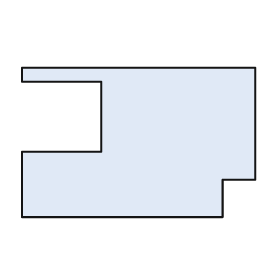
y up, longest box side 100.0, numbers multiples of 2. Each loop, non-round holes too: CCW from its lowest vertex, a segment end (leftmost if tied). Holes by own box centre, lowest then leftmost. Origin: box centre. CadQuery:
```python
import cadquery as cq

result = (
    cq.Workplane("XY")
    .moveTo(-50.0, -32.0)
    .lineTo(36.0, -32.0)
    .lineTo(36.0, -16.0)
    .lineTo(50.0, -16.0)
    .lineTo(50.0, 32.0)
    .lineTo(-50.0, 32.0)
    .lineTo(-50.0, 26.0)
    .lineTo(-16.0, 26.0)
    .lineTo(-16.0, -4.0)
    .lineTo(-50.0, -4.0)
    .close()
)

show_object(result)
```